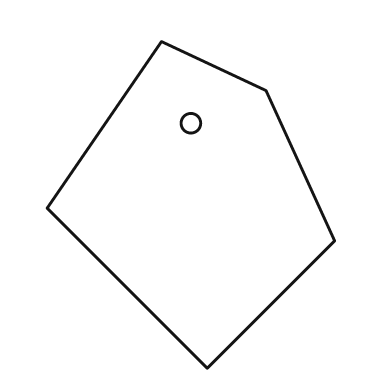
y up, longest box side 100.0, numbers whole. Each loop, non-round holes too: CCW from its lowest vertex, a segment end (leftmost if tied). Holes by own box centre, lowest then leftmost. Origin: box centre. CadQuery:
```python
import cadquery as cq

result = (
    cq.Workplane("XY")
    .moveTo(5.0, -50.0)
    .lineTo(44.0, -11.0)
    .lineTo(23.0, 35.0)
    .lineTo(-9.0, 50.0)
    .lineTo(-44.0, -1.0)
    .close()
    .moveTo(0.0, 25.0)
    .circle(3.0)
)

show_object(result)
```